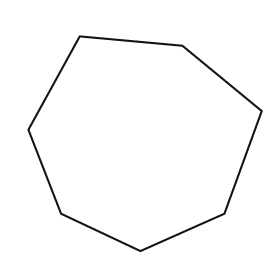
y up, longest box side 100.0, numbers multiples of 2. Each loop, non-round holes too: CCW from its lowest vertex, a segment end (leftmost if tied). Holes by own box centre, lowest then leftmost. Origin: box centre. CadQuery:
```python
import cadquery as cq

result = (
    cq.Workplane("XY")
    .moveTo(-2.0, -46.0)
    .lineTo(34.0, -30.0)
    .lineTo(50.0, 14.0)
    .lineTo(16.0, 42.0)
    .lineTo(-28.0, 46.0)
    .lineTo(-50.0, 6.0)
    .lineTo(-36.0, -30.0)
    .close()
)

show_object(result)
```